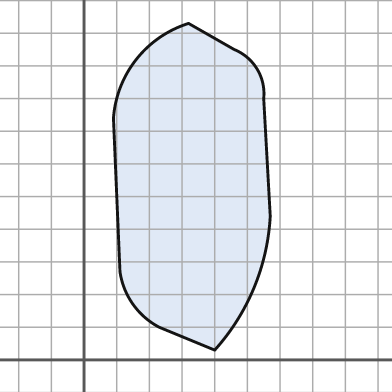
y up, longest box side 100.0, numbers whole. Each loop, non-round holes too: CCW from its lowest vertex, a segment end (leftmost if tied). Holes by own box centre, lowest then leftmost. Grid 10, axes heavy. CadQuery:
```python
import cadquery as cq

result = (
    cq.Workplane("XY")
    .moveTo(40.0, 3.0)
    .threePointArc((52.0, 22.0), (57.0, 44.0))
    .lineTo(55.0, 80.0)
    .threePointArc((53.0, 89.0), (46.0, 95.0))
    .lineTo(32.0, 103.0)
    .threePointArc((16.0, 92.0), (9.0, 74.0))
    .lineTo(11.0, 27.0)
    .threePointArc((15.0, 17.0), (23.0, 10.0))
    .close()
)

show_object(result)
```